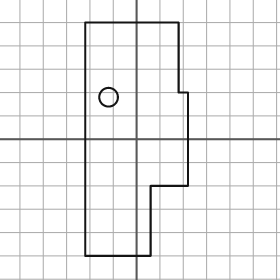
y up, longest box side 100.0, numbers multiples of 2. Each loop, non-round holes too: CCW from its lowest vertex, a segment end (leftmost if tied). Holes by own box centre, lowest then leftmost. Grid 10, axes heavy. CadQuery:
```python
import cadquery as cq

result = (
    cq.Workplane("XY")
    .moveTo(-22.0, -50.0)
    .lineTo(6.0, -50.0)
    .lineTo(6.0, -20.0)
    .lineTo(22.0, -20.0)
    .lineTo(22.0, 20.0)
    .lineTo(18.0, 20.0)
    .lineTo(18.0, 50.0)
    .lineTo(-22.0, 50.0)
    .close()
    .moveTo(-12.0, 18.0)
    .circle(4.0)
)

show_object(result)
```